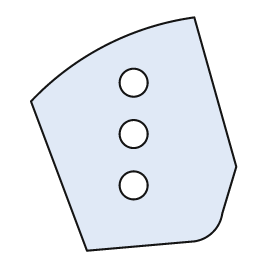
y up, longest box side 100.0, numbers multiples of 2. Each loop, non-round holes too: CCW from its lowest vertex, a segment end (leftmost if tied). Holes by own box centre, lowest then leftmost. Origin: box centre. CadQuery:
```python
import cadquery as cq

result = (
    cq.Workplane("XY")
    .moveTo(-20.0, -50.0)
    .lineTo(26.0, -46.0)
    .threePointArc((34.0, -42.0), (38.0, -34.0))
    .lineTo(44.0, -14.0)
    .lineTo(26.0, 50.0)
    .threePointArc((-12.0, 38.0), (-44.0, 14.0))
    .close()
    .moveTo(0.0, -22.0)
    .circle(6.0)
    .moveTo(0.0, 0.0)
    .circle(6.0)
    .moveTo(0.0, 22.0)
    .circle(6.0)
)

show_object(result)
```